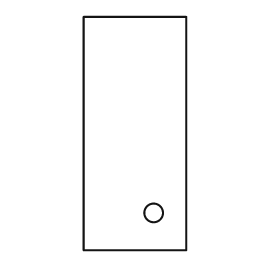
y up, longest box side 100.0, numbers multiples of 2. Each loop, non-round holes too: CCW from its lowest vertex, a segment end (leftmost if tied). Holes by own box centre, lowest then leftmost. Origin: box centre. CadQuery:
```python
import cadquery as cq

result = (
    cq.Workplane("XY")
    .moveTo(-22.0, -50.0)
    .lineTo(22.0, -50.0)
    .lineTo(22.0, 50.0)
    .lineTo(-22.0, 50.0)
    .close()
    .moveTo(8.0, -34.0)
    .circle(4.0)
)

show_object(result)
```